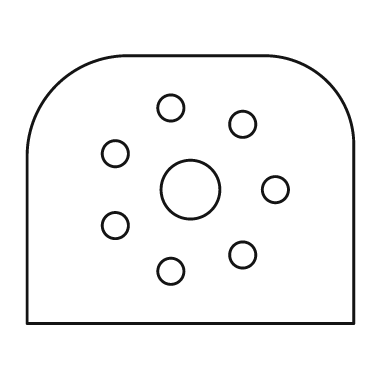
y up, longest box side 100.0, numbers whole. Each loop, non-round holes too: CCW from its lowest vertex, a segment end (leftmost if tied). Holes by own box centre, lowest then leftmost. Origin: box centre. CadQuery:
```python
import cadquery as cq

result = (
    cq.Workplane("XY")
    .moveTo(-50.0, -41.0)
    .lineTo(50.0, -41.0)
    .lineTo(50.0, 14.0)
    .threePointArc((42.0, 33.0), (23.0, 41.0))
    .lineTo(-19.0, 41.0)
    .threePointArc((-41.0, 32.0), (-50.0, 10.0))
    .close()
    .moveTo(-6.0, -25.0)
    .circle(4.0)
    .moveTo(16.0, -20.0)
    .circle(4.0)
    .moveTo(-23.0, -11.0)
    .circle(4.0)
    .moveTo(0.0, 0.0)
    .circle(9.0)
    .moveTo(26.0, 0.0)
    .circle(4.0)
    .moveTo(-23.0, 11.0)
    .circle(4.0)
    .moveTo(16.0, 20.0)
    .circle(4.0)
    .moveTo(-6.0, 25.0)
    .circle(4.0)
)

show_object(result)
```